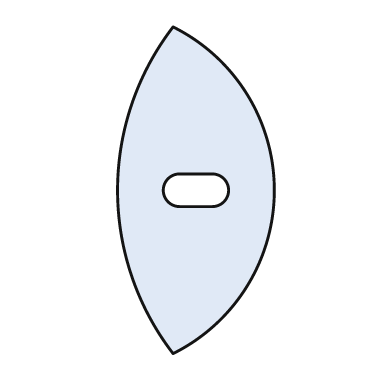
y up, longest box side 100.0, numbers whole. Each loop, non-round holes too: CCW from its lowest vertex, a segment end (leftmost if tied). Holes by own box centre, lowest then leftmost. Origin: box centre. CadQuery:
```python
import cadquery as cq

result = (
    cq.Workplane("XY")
    .moveTo(-7.0, -50.0)
    .threePointArc((24.0, 0.0), (-7.0, 50.0))
    .threePointArc((-24.0, 0.0), (-7.0, -50.0))
    .close()
    .moveTo(-5.0, -5.0)
    .lineTo(5.0, -5.0)
    .threePointArc((10.0, 0.0), (5.0, 5.0))
    .lineTo(-5.0, 5.0)
    .threePointArc((-10.0, 0.0), (-5.0, -5.0))
    .close()
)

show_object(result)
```